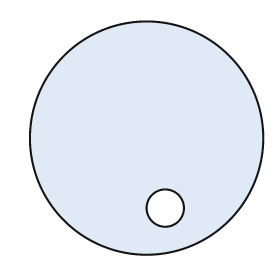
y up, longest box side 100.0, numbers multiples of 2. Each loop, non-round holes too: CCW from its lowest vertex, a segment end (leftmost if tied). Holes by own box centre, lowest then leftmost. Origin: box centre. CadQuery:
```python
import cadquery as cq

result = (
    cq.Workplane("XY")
    .moveTo(0.0, 0.0)
    .circle(50.0)
    .moveTo(8.0, -30.0)
    .circle(8.0)
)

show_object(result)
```